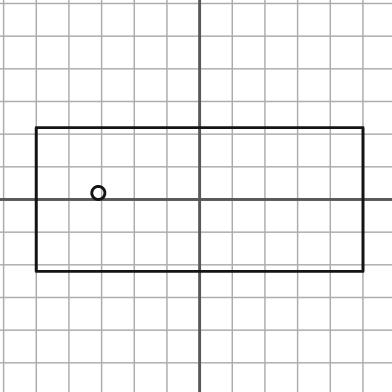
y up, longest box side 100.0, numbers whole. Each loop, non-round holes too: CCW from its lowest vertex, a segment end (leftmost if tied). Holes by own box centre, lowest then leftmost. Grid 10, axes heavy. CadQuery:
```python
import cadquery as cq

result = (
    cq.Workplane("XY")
    .moveTo(-50.0, -22.0)
    .lineTo(50.0, -22.0)
    .lineTo(50.0, 22.0)
    .lineTo(-50.0, 22.0)
    .close()
    .moveTo(-31.0, 2.0)
    .circle(2.0)
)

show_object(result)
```